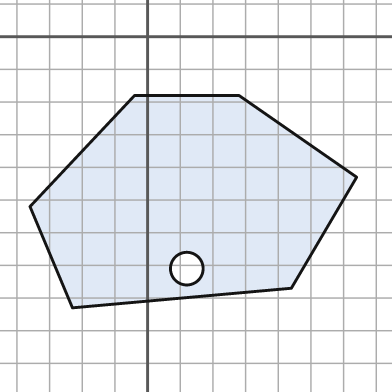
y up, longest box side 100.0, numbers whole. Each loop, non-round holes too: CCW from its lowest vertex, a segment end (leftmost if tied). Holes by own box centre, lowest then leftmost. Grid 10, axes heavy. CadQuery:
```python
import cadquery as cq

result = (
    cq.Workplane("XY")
    .moveTo(-23.0, -83.0)
    .lineTo(44.0, -77.0)
    .lineTo(64.0, -43.0)
    .lineTo(28.0, -18.0)
    .lineTo(-4.0, -18.0)
    .lineTo(-36.0, -52.0)
    .close()
    .moveTo(12.0, -71.0)
    .circle(5.0)
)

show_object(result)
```